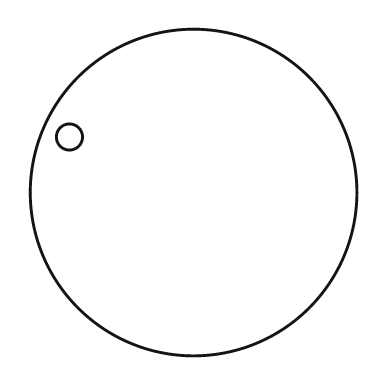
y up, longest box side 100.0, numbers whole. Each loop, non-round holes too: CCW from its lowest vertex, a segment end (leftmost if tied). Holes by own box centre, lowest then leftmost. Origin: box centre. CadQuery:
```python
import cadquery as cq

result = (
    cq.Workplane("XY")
    .moveTo(0.0, 0.0)
    .circle(50.0)
    .moveTo(-38.0, 17.0)
    .circle(4.0)
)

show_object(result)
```